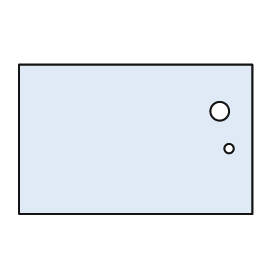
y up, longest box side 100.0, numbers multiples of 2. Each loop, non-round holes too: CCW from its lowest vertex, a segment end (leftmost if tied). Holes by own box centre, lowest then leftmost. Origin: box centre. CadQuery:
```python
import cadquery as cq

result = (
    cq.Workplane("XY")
    .moveTo(-50.0, -32.0)
    .lineTo(50.0, -32.0)
    .lineTo(50.0, 32.0)
    .lineTo(-50.0, 32.0)
    .close()
    .moveTo(40.0, -4.0)
    .circle(2.0)
    .moveTo(36.0, 12.0)
    .circle(4.0)
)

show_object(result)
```